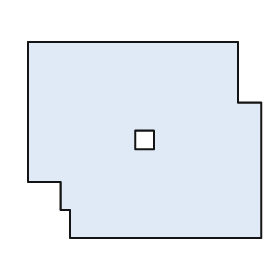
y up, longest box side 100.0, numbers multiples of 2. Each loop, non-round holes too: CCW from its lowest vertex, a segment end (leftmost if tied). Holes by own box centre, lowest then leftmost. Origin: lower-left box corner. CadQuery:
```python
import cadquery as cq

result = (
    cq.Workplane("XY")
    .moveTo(18.0, 0.0)
    .lineTo(100.0, 0.0)
    .lineTo(100.0, 58.0)
    .lineTo(90.0, 58.0)
    .lineTo(90.0, 84.0)
    .lineTo(0.0, 84.0)
    .lineTo(0.0, 24.0)
    .lineTo(14.0, 24.0)
    .lineTo(14.0, 12.0)
    .lineTo(18.0, 12.0)
    .close()
    .moveTo(46.0, 38.0)
    .lineTo(54.0, 38.0)
    .lineTo(54.0, 46.0)
    .lineTo(46.0, 46.0)
    .close()
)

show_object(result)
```